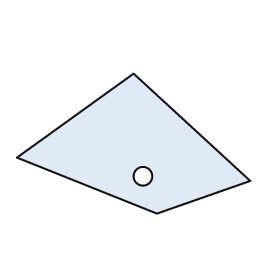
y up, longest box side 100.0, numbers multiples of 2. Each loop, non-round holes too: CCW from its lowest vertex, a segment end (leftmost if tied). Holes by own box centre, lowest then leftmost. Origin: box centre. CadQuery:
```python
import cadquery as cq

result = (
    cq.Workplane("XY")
    .moveTo(10.0, -30.0)
    .lineTo(50.0, -16.0)
    .lineTo(0.0, 30.0)
    .lineTo(-50.0, -6.0)
    .close()
    .moveTo(4.0, -14.0)
    .circle(4.0)
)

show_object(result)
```